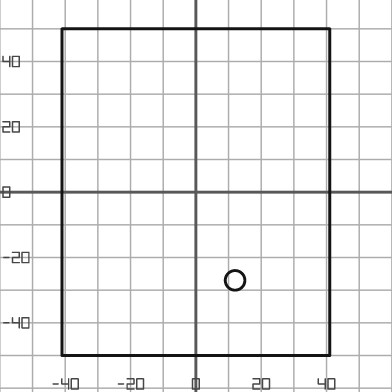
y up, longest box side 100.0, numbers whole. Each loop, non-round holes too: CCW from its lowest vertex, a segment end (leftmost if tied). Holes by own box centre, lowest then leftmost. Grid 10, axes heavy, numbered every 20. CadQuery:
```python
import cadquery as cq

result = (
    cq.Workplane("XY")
    .moveTo(-41.0, -50.0)
    .lineTo(41.0, -50.0)
    .lineTo(41.0, 50.0)
    .lineTo(-41.0, 50.0)
    .close()
    .moveTo(12.0, -27.0)
    .circle(3.0)
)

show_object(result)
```